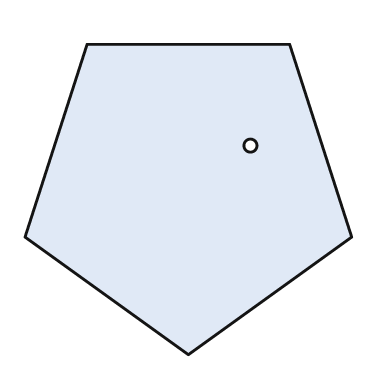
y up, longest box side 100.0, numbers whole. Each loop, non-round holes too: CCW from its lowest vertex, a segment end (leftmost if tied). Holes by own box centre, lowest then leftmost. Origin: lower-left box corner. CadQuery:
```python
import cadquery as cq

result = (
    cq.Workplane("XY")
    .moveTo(50.0, 0.0)
    .lineTo(100.0, 36.0)
    .lineTo(81.0, 95.0)
    .lineTo(19.0, 95.0)
    .lineTo(0.0, 36.0)
    .close()
    .moveTo(69.0, 64.0)
    .circle(2.0)
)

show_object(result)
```